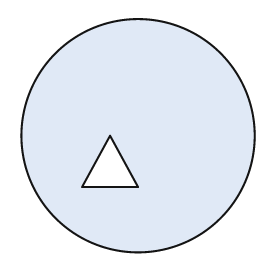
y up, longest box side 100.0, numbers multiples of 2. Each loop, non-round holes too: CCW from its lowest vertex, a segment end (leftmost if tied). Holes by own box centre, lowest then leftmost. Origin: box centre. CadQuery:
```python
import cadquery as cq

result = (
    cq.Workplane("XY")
    .moveTo(0.0, 0.0)
    .circle(50.0)
    .moveTo(-24.0, -22.0)
    .lineTo(0.0, -22.0)
    .lineTo(-12.0, 0.0)
    .close()
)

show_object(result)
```